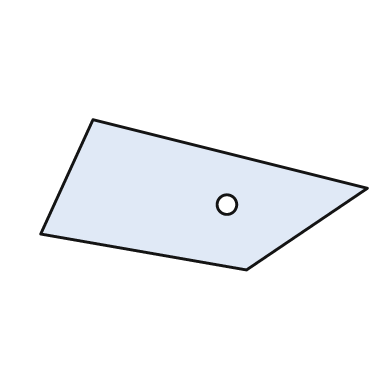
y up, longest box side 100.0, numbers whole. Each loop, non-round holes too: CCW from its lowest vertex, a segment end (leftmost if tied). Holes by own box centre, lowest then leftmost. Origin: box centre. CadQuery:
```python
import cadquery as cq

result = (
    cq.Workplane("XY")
    .moveTo(13.0, -23.0)
    .lineTo(50.0, 2.0)
    .lineTo(-34.0, 23.0)
    .lineTo(-50.0, -12.0)
    .close()
    .moveTo(7.0, -3.0)
    .circle(3.0)
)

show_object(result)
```